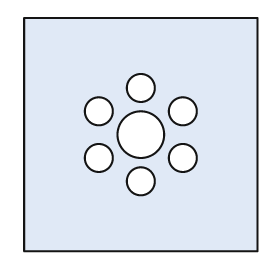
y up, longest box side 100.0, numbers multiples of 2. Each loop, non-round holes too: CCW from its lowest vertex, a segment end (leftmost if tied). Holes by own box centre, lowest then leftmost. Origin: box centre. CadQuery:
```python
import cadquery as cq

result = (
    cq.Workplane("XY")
    .moveTo(-50.0, -50.0)
    .lineTo(50.0, -50.0)
    .lineTo(50.0, 50.0)
    .lineTo(-50.0, 50.0)
    .close()
    .moveTo(0.0, -20.0)
    .circle(6.0)
    .moveTo(-18.0, -10.0)
    .circle(6.0)
    .moveTo(18.0, -10.0)
    .circle(6.0)
    .moveTo(0.0, 0.0)
    .circle(10.0)
    .moveTo(-18.0, 10.0)
    .circle(6.0)
    .moveTo(18.0, 10.0)
    .circle(6.0)
    .moveTo(0.0, 20.0)
    .circle(6.0)
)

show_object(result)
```